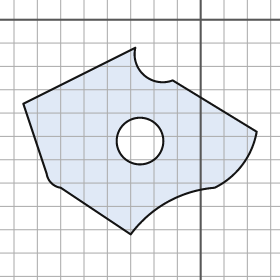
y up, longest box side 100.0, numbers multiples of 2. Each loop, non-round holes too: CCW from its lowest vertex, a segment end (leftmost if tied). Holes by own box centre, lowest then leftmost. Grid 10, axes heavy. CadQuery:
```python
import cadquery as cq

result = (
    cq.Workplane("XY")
    .moveTo(-30.0, -92.0)
    .threePointArc((-14.0, -78.0), (6.0, -72.0))
    .threePointArc((18.0, -62.0), (24.0, -48.0))
    .lineTo(-12.0, -26.0)
    .threePointArc((-24.0, -24.0), (-28.0, -12.0))
    .lineTo(-76.0, -36.0)
    .lineTo(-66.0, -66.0)
    .threePointArc((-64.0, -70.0), (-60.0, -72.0))
    .close()
    .moveTo(-26.0, -52.0)
    .circle(10.0)
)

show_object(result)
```